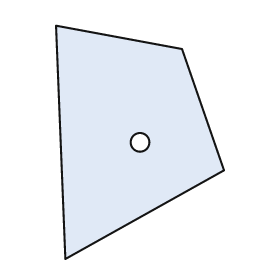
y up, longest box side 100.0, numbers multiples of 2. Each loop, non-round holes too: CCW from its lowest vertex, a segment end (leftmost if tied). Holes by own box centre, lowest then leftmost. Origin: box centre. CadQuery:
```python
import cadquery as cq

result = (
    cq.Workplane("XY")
    .moveTo(-32.0, -50.0)
    .lineTo(36.0, -12.0)
    .lineTo(18.0, 40.0)
    .lineTo(-36.0, 50.0)
    .close()
    .moveTo(0.0, 0.0)
    .circle(4.0)
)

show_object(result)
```